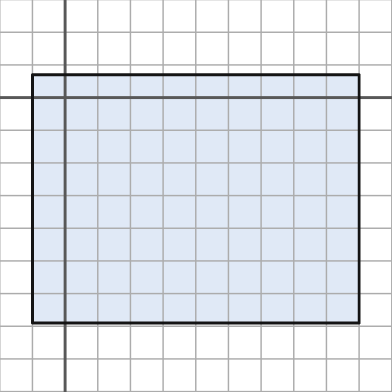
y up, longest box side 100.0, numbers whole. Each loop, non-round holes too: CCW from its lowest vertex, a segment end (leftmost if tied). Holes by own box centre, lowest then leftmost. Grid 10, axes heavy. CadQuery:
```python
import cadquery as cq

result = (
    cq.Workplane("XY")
    .moveTo(-10.0, -69.0)
    .lineTo(90.0, -69.0)
    .lineTo(90.0, 7.0)
    .lineTo(-10.0, 7.0)
    .close()
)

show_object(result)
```